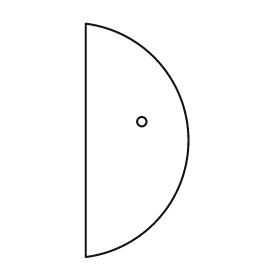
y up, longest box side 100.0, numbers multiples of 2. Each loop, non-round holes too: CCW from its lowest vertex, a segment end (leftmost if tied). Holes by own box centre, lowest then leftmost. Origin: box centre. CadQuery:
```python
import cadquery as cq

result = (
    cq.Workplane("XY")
    .moveTo(-22.0, -50.0)
    .threePointArc((22.0, 0.0), (-22.0, 50.0))
    .close()
    .moveTo(2.0, 8.0)
    .circle(2.0)
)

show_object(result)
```